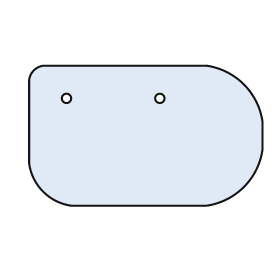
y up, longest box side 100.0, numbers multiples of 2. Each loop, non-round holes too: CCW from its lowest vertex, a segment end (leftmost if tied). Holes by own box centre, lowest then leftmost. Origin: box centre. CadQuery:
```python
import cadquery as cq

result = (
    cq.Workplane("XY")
    .moveTo(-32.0, -30.0)
    .lineTo(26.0, -30.0)
    .threePointArc((42.0, -22.0), (50.0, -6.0))
    .lineTo(50.0, 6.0)
    .threePointArc((42.0, 22.0), (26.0, 30.0))
    .lineTo(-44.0, 30.0)
    .threePointArc((-48.0, 28.0), (-50.0, 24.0))
    .lineTo(-50.0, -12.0)
    .threePointArc((-44.0, -24.0), (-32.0, -30.0))
    .close()
    .moveTo(-34.0, 16.0)
    .circle(2.0)
    .moveTo(6.0, 16.0)
    .circle(2.0)
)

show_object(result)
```